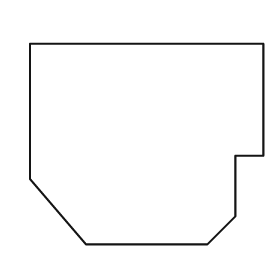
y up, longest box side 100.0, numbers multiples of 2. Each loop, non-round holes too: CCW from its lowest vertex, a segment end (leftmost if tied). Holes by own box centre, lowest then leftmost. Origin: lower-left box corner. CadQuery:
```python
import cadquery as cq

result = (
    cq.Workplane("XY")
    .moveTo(24.0, 0.0)
    .lineTo(76.0, 0.0)
    .lineTo(88.0, 12.0)
    .lineTo(88.0, 38.0)
    .lineTo(100.0, 38.0)
    .lineTo(100.0, 86.0)
    .lineTo(0.0, 86.0)
    .lineTo(0.0, 28.0)
    .close()
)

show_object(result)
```